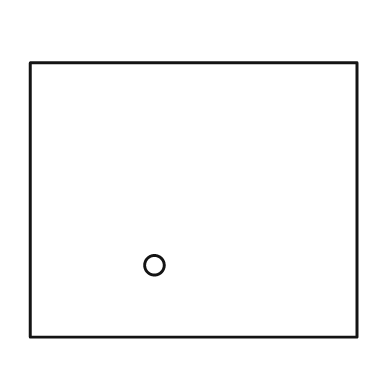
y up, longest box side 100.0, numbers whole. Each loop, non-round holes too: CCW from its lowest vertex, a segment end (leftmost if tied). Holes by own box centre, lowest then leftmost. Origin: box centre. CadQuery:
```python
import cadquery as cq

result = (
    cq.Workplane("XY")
    .moveTo(-50.0, -42.0)
    .lineTo(50.0, -42.0)
    .lineTo(50.0, 42.0)
    .lineTo(-50.0, 42.0)
    .close()
    .moveTo(-12.0, -20.0)
    .circle(3.0)
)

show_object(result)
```